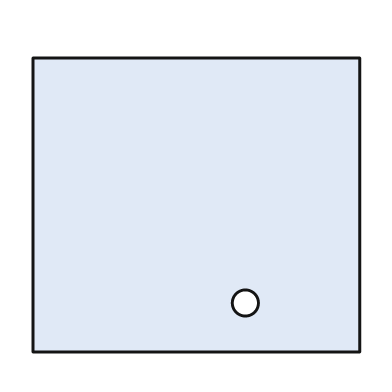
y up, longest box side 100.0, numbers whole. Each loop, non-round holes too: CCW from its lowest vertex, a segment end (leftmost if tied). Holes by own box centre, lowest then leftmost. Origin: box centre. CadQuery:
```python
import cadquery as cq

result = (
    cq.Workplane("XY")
    .moveTo(-50.0, -45.0)
    .lineTo(50.0, -45.0)
    .lineTo(50.0, 45.0)
    .lineTo(-50.0, 45.0)
    .close()
    .moveTo(15.0, -30.0)
    .circle(4.0)
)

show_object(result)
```